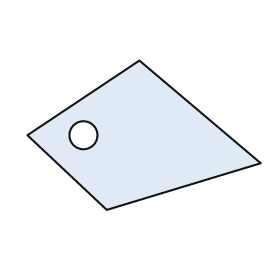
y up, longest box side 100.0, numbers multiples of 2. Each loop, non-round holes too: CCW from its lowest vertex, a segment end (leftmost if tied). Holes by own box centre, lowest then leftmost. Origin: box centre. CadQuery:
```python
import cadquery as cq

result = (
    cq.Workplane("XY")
    .moveTo(-16.0, -32.0)
    .lineTo(50.0, -12.0)
    .lineTo(-2.0, 32.0)
    .lineTo(-50.0, 0.0)
    .close()
    .moveTo(-26.0, 0.0)
    .circle(6.0)
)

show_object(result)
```